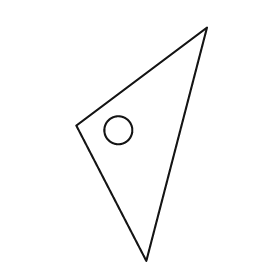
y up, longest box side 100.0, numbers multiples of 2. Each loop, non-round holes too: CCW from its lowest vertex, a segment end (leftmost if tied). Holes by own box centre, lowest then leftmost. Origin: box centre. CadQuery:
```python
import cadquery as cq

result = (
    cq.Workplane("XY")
    .moveTo(2.0, -50.0)
    .lineTo(28.0, 50.0)
    .lineTo(-28.0, 8.0)
    .close()
    .moveTo(-10.0, 6.0)
    .circle(6.0)
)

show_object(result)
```